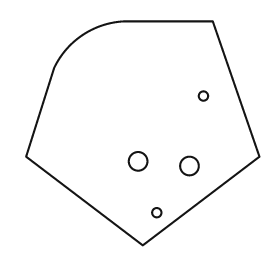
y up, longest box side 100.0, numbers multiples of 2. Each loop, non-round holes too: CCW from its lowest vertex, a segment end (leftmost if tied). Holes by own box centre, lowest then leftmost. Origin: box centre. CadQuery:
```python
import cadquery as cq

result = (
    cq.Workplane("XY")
    .moveTo(0.0, -48.0)
    .lineTo(50.0, -10.0)
    .lineTo(30.0, 48.0)
    .lineTo(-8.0, 48.0)
    .threePointArc((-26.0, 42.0), (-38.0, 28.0))
    .lineTo(-50.0, -10.0)
    .close()
    .moveTo(6.0, -34.0)
    .circle(2.0)
    .moveTo(20.0, -14.0)
    .circle(4.0)
    .moveTo(-2.0, -12.0)
    .circle(4.0)
    .moveTo(26.0, 16.0)
    .circle(2.0)
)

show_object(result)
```